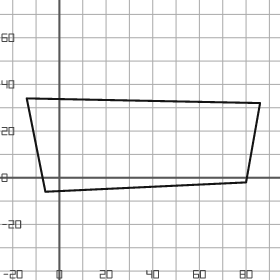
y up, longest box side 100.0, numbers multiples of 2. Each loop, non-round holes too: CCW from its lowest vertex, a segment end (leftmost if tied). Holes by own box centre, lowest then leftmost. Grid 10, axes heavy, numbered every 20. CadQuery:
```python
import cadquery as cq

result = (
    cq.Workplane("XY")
    .moveTo(-6.0, -6.0)
    .lineTo(80.0, -2.0)
    .lineTo(86.0, 32.0)
    .lineTo(-14.0, 34.0)
    .close()
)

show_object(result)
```